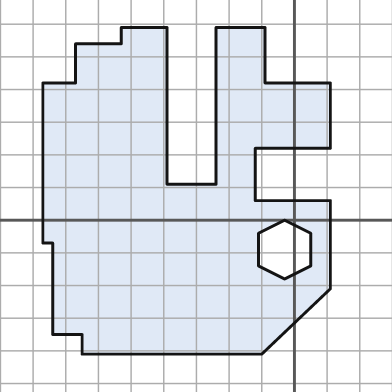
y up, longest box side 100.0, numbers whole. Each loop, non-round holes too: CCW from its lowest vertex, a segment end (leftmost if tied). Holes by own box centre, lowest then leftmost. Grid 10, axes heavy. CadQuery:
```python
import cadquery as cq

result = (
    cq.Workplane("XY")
    .moveTo(-65.0, -41.0)
    .lineTo(-10.0, -41.0)
    .lineTo(11.0, -21.0)
    .lineTo(11.0, 6.0)
    .lineTo(-12.0, 6.0)
    .lineTo(-12.0, 22.0)
    .lineTo(11.0, 22.0)
    .lineTo(11.0, 42.0)
    .lineTo(-9.0, 42.0)
    .lineTo(-9.0, 59.0)
    .lineTo(-24.0, 59.0)
    .lineTo(-24.0, 11.0)
    .lineTo(-39.0, 11.0)
    .lineTo(-39.0, 59.0)
    .lineTo(-53.0, 59.0)
    .lineTo(-53.0, 54.0)
    .lineTo(-67.0, 54.0)
    .lineTo(-67.0, 42.0)
    .lineTo(-77.0, 42.0)
    .lineTo(-77.0, -7.0)
    .lineTo(-74.0, -7.0)
    .lineTo(-74.0, -35.0)
    .lineTo(-65.0, -35.0)
    .close()
    .moveTo(-3.0, -18.0)
    .lineTo(5.0, -14.0)
    .lineTo(5.0, -4.0)
    .lineTo(-3.0, 0.0)
    .lineTo(-11.0, -4.0)
    .lineTo(-11.0, -14.0)
    .close()
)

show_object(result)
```